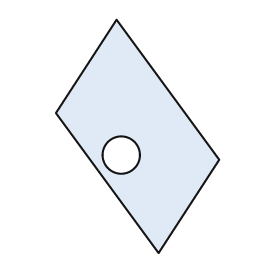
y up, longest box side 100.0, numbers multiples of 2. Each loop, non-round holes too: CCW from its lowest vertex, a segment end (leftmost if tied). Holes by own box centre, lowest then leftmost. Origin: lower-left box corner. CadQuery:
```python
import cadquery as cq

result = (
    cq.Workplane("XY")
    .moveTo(44.0, 0.0)
    .lineTo(70.0, 40.0)
    .lineTo(26.0, 100.0)
    .lineTo(0.0, 60.0)
    .close()
    .moveTo(28.0, 42.0)
    .circle(8.0)
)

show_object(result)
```